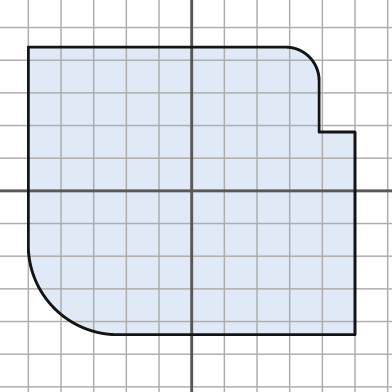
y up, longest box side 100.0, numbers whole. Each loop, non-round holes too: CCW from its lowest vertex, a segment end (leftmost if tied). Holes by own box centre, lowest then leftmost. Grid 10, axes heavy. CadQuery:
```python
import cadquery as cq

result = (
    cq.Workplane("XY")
    .moveTo(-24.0, -44.0)
    .lineTo(50.0, -44.0)
    .lineTo(50.0, 18.0)
    .lineTo(39.0, 18.0)
    .lineTo(39.0, 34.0)
    .threePointArc((36.0, 41.0), (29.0, 44.0))
    .lineTo(-50.0, 44.0)
    .lineTo(-50.0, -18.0)
    .threePointArc((-42.0, -36.0), (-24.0, -44.0))
    .close()
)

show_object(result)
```